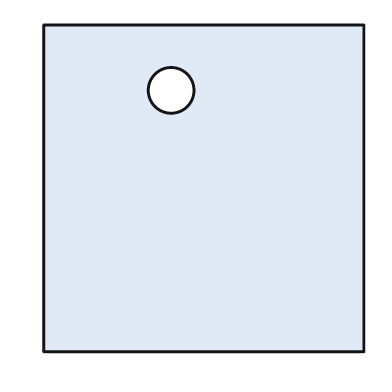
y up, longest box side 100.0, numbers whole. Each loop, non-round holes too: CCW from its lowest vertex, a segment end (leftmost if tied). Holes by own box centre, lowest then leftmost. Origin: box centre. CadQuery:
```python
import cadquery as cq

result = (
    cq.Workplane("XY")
    .moveTo(-49.0, -50.0)
    .lineTo(49.0, -50.0)
    .lineTo(49.0, 50.0)
    .lineTo(-49.0, 50.0)
    .close()
    .moveTo(-10.0, 30.0)
    .circle(7.0)
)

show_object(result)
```